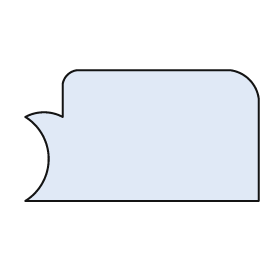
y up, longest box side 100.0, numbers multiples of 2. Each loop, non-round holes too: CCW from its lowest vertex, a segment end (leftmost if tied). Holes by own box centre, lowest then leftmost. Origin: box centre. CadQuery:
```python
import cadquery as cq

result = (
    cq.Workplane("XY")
    .moveTo(-50.0, -28.0)
    .lineTo(50.0, -28.0)
    .lineTo(50.0, 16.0)
    .threePointArc((46.0, 24.0), (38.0, 28.0))
    .lineTo(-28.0, 28.0)
    .threePointArc((-32.0, 26.0), (-34.0, 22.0))
    .lineTo(-34.0, 8.0)
    .threePointArc((-42.0, 10.0), (-50.0, 8.0))
    .threePointArc((-40.0, -10.0), (-50.0, -28.0))
    .close()
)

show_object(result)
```